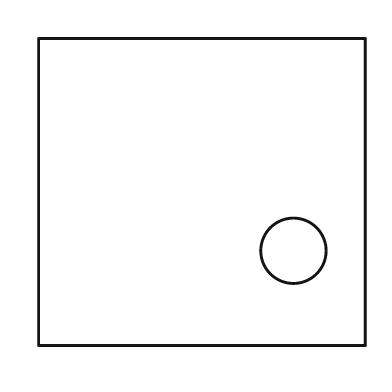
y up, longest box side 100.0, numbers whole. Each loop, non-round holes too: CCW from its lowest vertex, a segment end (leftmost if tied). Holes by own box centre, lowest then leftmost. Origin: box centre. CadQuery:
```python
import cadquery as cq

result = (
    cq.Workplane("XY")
    .moveTo(-50.0, -47.0)
    .lineTo(50.0, -47.0)
    .lineTo(50.0, 47.0)
    .lineTo(-50.0, 47.0)
    .close()
    .moveTo(28.0, -18.0)
    .circle(10.0)
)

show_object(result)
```